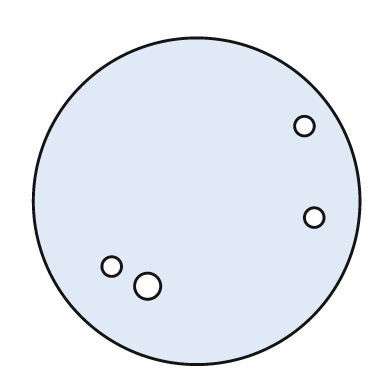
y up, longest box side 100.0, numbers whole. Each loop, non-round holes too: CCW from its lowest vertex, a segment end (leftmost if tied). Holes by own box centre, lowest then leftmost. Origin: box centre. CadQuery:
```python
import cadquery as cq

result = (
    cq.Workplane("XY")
    .moveTo(0.0, 0.0)
    .circle(50.0)
    .moveTo(-15.0, -26.0)
    .circle(4.0)
    .moveTo(-26.0, -20.0)
    .circle(3.0)
    .moveTo(36.0, -5.0)
    .circle(3.0)
    .moveTo(33.0, 23.0)
    .circle(3.0)
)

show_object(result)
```